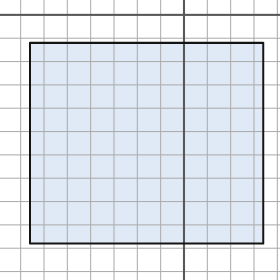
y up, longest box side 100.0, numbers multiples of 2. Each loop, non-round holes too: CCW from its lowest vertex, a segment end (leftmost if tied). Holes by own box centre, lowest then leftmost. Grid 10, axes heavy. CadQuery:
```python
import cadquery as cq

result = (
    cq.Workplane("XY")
    .moveTo(-66.0, -98.0)
    .lineTo(34.0, -98.0)
    .lineTo(34.0, -12.0)
    .lineTo(-66.0, -12.0)
    .close()
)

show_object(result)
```